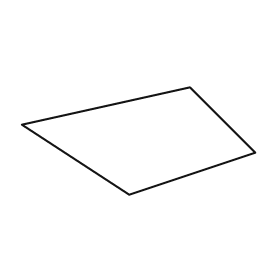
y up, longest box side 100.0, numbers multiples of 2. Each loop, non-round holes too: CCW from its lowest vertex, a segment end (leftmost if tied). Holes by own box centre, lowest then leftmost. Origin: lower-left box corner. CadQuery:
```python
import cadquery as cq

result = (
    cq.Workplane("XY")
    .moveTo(46.0, 0.0)
    .lineTo(100.0, 18.0)
    .lineTo(72.0, 46.0)
    .lineTo(0.0, 30.0)
    .close()
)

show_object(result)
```